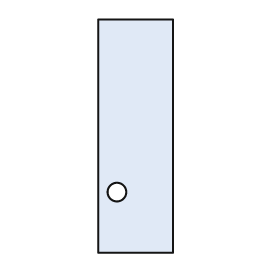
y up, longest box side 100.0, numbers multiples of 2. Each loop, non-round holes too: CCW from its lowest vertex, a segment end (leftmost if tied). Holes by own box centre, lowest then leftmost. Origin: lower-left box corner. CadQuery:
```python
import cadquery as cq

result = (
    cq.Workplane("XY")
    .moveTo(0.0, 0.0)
    .lineTo(32.0, 0.0)
    .lineTo(32.0, 100.0)
    .lineTo(0.0, 100.0)
    .close()
    .moveTo(8.0, 26.0)
    .circle(4.0)
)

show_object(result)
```